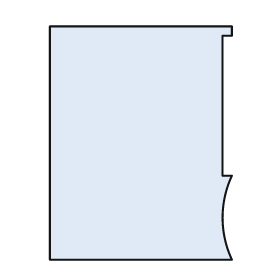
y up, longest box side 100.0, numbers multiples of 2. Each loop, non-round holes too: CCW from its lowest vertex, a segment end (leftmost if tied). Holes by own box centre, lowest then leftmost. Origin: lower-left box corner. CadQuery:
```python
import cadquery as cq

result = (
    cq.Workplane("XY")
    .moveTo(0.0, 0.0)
    .lineTo(78.0, 0.0)
    .threePointArc((74.0, 18.0), (78.0, 36.0))
    .lineTo(74.0, 36.0)
    .lineTo(74.0, 96.0)
    .lineTo(78.0, 96.0)
    .lineTo(78.0, 100.0)
    .lineTo(0.0, 100.0)
    .close()
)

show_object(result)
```